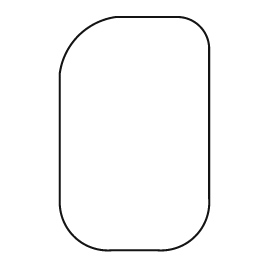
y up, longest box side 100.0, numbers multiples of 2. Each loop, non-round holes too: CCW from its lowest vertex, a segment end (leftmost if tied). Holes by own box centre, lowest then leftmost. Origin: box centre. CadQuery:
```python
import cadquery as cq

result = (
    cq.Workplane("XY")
    .moveTo(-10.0, -50.0)
    .lineTo(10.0, -50.0)
    .threePointArc((26.0, -44.0), (32.0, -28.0))
    .lineTo(32.0, 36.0)
    .threePointArc((28.0, 46.0), (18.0, 50.0))
    .lineTo(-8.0, 50.0)
    .threePointArc((-24.0, 42.0), (-32.0, 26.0))
    .lineTo(-32.0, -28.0)
    .threePointArc((-26.0, -44.0), (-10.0, -50.0))
    .close()
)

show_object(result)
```